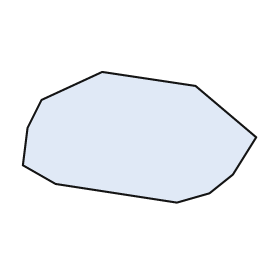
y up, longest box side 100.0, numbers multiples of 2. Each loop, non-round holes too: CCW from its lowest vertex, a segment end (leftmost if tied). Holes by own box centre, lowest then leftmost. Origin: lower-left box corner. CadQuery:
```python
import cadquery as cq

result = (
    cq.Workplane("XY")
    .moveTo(66.0, 0.0)
    .lineTo(80.0, 4.0)
    .lineTo(90.0, 12.0)
    .lineTo(100.0, 28.0)
    .lineTo(74.0, 50.0)
    .lineTo(34.0, 56.0)
    .lineTo(8.0, 44.0)
    .lineTo(2.0, 32.0)
    .lineTo(0.0, 16.0)
    .lineTo(14.0, 8.0)
    .close()
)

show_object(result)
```